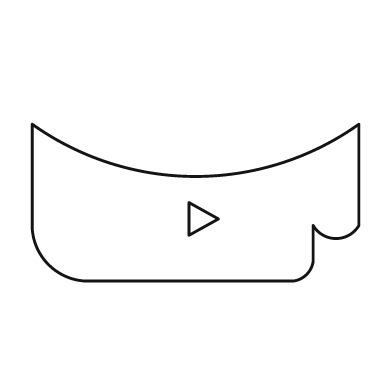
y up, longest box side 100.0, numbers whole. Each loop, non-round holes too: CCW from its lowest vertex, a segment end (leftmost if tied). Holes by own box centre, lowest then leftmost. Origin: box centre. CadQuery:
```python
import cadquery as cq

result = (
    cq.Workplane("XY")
    .moveTo(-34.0, -24.0)
    .lineTo(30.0, -24.0)
    .threePointArc((34.0, -22.0), (36.0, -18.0))
    .lineTo(36.0, -7.0)
    .threePointArc((43.0, -11.0), (50.0, -7.0))
    .lineTo(50.0, 24.0)
    .threePointArc((0.0, 8.0), (-50.0, 24.0))
    .lineTo(-50.0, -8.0)
    .threePointArc((-45.0, -19.0), (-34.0, -24.0))
    .close()
    .moveTo(-2.0, -10.0)
    .lineTo(7.0, -5.0)
    .lineTo(-2.0, 0.0)
    .close()
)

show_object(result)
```